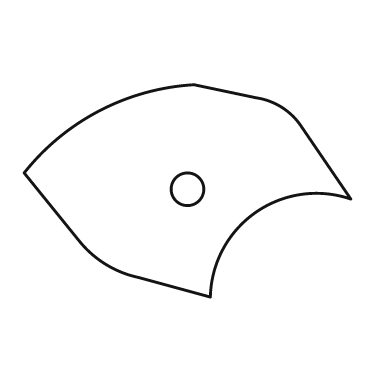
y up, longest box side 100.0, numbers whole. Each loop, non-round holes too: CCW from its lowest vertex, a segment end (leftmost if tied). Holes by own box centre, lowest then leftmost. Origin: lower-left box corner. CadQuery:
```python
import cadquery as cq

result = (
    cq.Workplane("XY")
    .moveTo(57.0, 0.0)
    .threePointArc((71.0, 26.0), (100.0, 30.0))
    .lineTo(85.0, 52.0)
    .threePointArc((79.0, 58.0), (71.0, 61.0))
    .lineTo(52.0, 65.0)
    .threePointArc((23.0, 57.0), (0.0, 38.0))
    .lineTo(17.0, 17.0)
    .threePointArc((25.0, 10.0), (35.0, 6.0))
    .close()
    .moveTo(50.0, 33.0)
    .circle(5.0)
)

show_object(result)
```